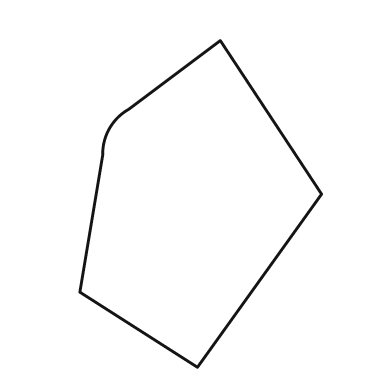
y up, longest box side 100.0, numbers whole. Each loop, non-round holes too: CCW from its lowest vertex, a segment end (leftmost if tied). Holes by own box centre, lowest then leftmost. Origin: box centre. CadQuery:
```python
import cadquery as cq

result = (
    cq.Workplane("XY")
    .moveTo(-1.0, -50.0)
    .lineTo(37.0, 3.0)
    .lineTo(6.0, 50.0)
    .lineTo(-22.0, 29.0)
    .threePointArc((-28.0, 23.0), (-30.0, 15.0))
    .lineTo(-37.0, -27.0)
    .close()
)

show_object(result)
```